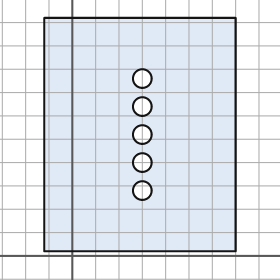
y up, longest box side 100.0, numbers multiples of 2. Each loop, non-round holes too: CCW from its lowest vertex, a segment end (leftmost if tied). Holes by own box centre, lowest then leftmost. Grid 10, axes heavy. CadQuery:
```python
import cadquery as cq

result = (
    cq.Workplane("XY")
    .moveTo(-12.0, 2.0)
    .lineTo(70.0, 2.0)
    .lineTo(70.0, 102.0)
    .lineTo(-12.0, 102.0)
    .close()
    .moveTo(30.0, 28.0)
    .circle(4.0)
    .moveTo(30.0, 40.0)
    .circle(4.0)
    .moveTo(30.0, 52.0)
    .circle(4.0)
    .moveTo(30.0, 64.0)
    .circle(4.0)
    .moveTo(30.0, 76.0)
    .circle(4.0)
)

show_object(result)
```